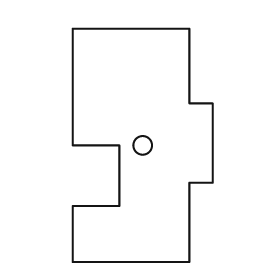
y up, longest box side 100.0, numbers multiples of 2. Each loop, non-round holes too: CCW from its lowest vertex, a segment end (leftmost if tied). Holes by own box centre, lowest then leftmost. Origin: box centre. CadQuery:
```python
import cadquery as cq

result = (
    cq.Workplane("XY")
    .moveTo(-30.0, -50.0)
    .lineTo(20.0, -50.0)
    .lineTo(20.0, -16.0)
    .lineTo(30.0, -16.0)
    .lineTo(30.0, 18.0)
    .lineTo(20.0, 18.0)
    .lineTo(20.0, 50.0)
    .lineTo(-30.0, 50.0)
    .lineTo(-30.0, 0.0)
    .lineTo(-10.0, 0.0)
    .lineTo(-10.0, -26.0)
    .lineTo(-30.0, -26.0)
    .close()
    .moveTo(0.0, 0.0)
    .circle(4.0)
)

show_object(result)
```